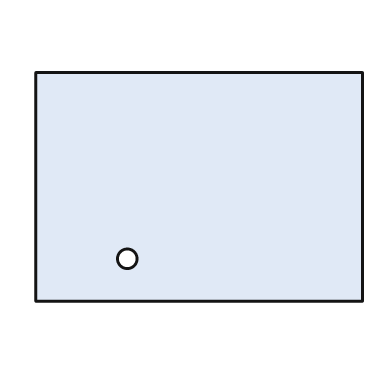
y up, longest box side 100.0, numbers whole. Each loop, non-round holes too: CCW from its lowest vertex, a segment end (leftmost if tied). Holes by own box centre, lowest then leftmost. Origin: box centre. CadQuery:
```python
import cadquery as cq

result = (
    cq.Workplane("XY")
    .moveTo(-50.0, -35.0)
    .lineTo(50.0, -35.0)
    .lineTo(50.0, 35.0)
    .lineTo(-50.0, 35.0)
    .close()
    .moveTo(-22.0, -22.0)
    .circle(3.0)
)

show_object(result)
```